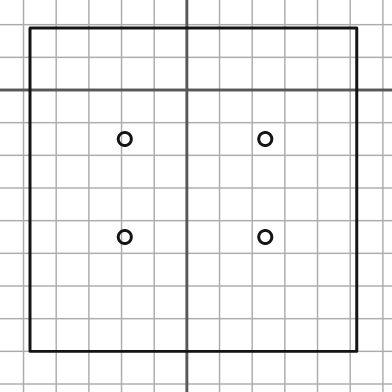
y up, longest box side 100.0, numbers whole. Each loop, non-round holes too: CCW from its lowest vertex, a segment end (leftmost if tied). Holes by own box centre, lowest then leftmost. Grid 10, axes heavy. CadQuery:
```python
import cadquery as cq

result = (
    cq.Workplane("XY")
    .moveTo(-48.0, -80.0)
    .lineTo(52.0, -80.0)
    .lineTo(52.0, 19.0)
    .lineTo(-48.0, 19.0)
    .close()
    .moveTo(-19.0, -45.0)
    .circle(2.0)
    .moveTo(24.0, -45.0)
    .circle(2.0)
    .moveTo(-19.0, -15.0)
    .circle(2.0)
    .moveTo(24.0, -15.0)
    .circle(2.0)
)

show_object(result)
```